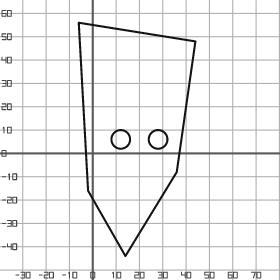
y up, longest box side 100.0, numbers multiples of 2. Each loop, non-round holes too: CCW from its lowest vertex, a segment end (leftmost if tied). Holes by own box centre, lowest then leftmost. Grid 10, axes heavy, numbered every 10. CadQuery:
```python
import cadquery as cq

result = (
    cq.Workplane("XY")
    .moveTo(14.0, -44.0)
    .lineTo(36.0, -8.0)
    .lineTo(44.0, 48.0)
    .lineTo(-6.0, 56.0)
    .lineTo(-2.0, -16.0)
    .close()
    .moveTo(12.0, 6.0)
    .circle(4.0)
    .moveTo(28.0, 6.0)
    .circle(4.0)
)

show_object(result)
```